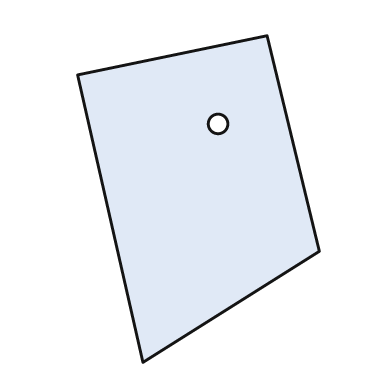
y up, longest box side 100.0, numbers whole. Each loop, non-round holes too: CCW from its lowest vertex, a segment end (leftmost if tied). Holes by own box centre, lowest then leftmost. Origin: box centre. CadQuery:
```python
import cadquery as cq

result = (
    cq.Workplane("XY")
    .moveTo(-17.0, -50.0)
    .lineTo(37.0, -16.0)
    .lineTo(21.0, 50.0)
    .lineTo(-37.0, 38.0)
    .close()
    .moveTo(6.0, 23.0)
    .circle(3.0)
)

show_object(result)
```